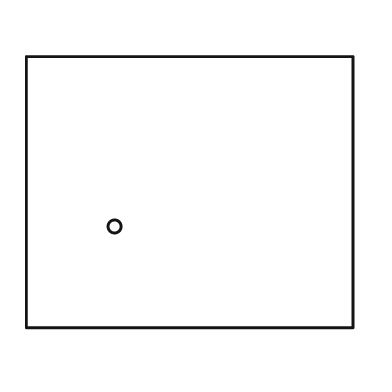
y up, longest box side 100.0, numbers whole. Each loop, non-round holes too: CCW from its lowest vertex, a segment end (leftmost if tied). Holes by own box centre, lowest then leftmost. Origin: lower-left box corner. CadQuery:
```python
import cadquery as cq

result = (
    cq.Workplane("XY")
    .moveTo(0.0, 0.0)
    .lineTo(100.0, 0.0)
    .lineTo(100.0, 83.0)
    .lineTo(0.0, 83.0)
    .close()
    .moveTo(27.0, 31.0)
    .circle(2.0)
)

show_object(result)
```